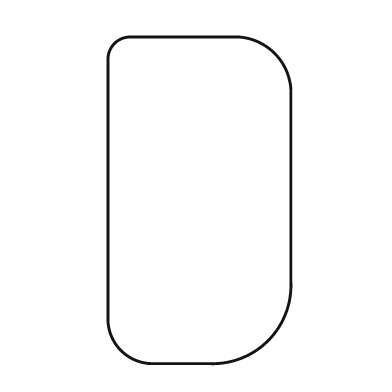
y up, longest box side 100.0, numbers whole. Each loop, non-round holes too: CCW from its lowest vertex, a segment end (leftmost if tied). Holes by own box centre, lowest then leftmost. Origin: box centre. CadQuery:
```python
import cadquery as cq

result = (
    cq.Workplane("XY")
    .moveTo(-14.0, -50.0)
    .lineTo(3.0, -50.0)
    .threePointArc((21.0, -43.0), (28.0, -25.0))
    .lineTo(28.0, 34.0)
    .threePointArc((23.0, 45.0), (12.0, 50.0))
    .lineTo(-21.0, 50.0)
    .threePointArc((-26.0, 48.0), (-28.0, 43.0))
    .lineTo(-28.0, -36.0)
    .threePointArc((-24.0, -46.0), (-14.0, -50.0))
    .close()
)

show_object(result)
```